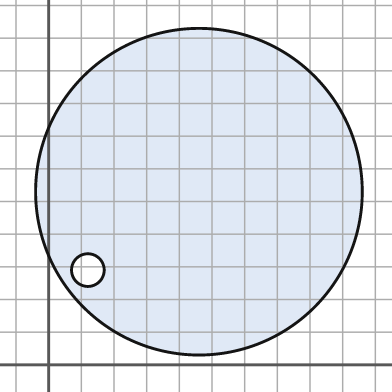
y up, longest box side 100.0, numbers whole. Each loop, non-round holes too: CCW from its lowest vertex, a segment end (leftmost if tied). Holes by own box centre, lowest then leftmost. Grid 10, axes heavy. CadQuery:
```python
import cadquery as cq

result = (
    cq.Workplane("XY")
    .moveTo(46.0, 53.0)
    .circle(50.0)
    .moveTo(12.0, 29.0)
    .circle(5.0)
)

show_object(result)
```